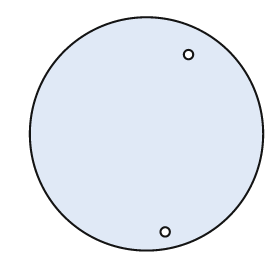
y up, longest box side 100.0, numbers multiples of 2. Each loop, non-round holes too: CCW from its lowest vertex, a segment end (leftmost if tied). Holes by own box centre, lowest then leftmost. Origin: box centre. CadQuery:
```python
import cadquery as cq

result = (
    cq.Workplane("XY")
    .moveTo(0.0, 0.0)
    .circle(50.0)
    .moveTo(8.0, -42.0)
    .circle(2.0)
    .moveTo(18.0, 34.0)
    .circle(2.0)
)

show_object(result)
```